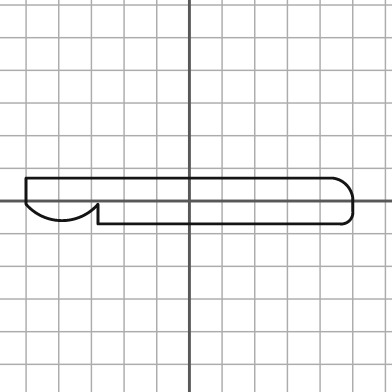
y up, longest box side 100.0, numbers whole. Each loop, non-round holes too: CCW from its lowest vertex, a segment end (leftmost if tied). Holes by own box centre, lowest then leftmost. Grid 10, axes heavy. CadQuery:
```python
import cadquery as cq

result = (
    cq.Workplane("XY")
    .moveTo(-28.0, -7.0)
    .lineTo(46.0, -7.0)
    .threePointArc((49.0, -6.0), (50.0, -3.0))
    .lineTo(50.0, 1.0)
    .threePointArc((48.0, 5.0), (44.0, 7.0))
    .lineTo(-50.0, 7.0)
    .lineTo(-50.0, -1.0)
    .threePointArc((-39.0, -6.0), (-28.0, -1.0))
    .close()
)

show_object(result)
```